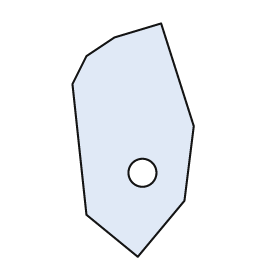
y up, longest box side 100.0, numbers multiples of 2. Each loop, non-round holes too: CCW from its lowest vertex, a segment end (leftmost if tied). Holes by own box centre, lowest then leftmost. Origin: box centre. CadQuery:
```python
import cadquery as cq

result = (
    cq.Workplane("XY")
    .moveTo(2.0, -50.0)
    .lineTo(22.0, -26.0)
    .lineTo(26.0, 6.0)
    .lineTo(12.0, 50.0)
    .lineTo(-8.0, 44.0)
    .lineTo(-20.0, 36.0)
    .lineTo(-26.0, 24.0)
    .lineTo(-20.0, -32.0)
    .close()
    .moveTo(4.0, -14.0)
    .circle(6.0)
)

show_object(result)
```